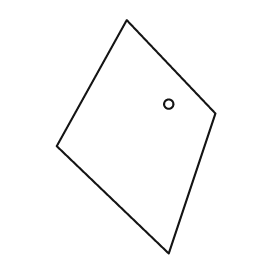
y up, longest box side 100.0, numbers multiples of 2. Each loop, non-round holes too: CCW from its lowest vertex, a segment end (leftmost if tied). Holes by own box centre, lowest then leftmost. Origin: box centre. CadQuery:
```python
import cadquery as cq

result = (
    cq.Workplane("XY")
    .moveTo(14.0, -50.0)
    .lineTo(34.0, 10.0)
    .lineTo(-4.0, 50.0)
    .lineTo(-34.0, -4.0)
    .close()
    .moveTo(14.0, 14.0)
    .circle(2.0)
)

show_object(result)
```